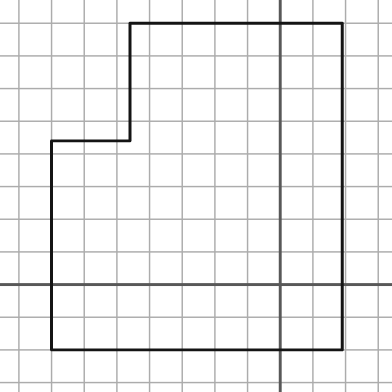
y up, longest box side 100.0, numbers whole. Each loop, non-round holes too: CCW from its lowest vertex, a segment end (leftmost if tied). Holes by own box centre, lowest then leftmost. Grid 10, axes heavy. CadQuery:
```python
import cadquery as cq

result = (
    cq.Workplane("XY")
    .moveTo(-70.0, -20.0)
    .lineTo(19.0, -20.0)
    .lineTo(19.0, 80.0)
    .lineTo(-46.0, 80.0)
    .lineTo(-46.0, 44.0)
    .lineTo(-70.0, 44.0)
    .close()
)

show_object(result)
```